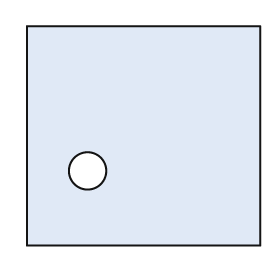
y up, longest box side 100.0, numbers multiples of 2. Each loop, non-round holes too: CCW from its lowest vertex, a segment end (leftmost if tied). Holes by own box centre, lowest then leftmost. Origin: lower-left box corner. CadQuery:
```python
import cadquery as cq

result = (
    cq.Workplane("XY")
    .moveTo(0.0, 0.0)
    .lineTo(100.0, 0.0)
    .lineTo(100.0, 94.0)
    .lineTo(0.0, 94.0)
    .close()
    .moveTo(26.0, 32.0)
    .circle(8.0)
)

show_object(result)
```